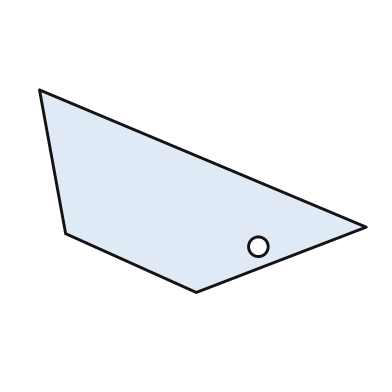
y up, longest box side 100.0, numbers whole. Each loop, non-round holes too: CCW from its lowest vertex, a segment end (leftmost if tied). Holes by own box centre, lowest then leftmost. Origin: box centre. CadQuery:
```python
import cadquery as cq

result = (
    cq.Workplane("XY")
    .moveTo(-2.0, -31.0)
    .lineTo(50.0, -11.0)
    .lineTo(-50.0, 31.0)
    .lineTo(-42.0, -13.0)
    .close()
    .moveTo(17.0, -17.0)
    .circle(3.0)
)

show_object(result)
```